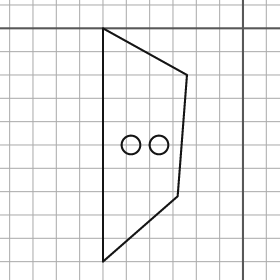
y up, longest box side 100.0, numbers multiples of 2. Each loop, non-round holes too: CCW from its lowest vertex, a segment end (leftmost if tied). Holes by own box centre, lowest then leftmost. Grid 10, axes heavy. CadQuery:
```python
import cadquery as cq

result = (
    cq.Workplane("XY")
    .moveTo(-60.0, -100.0)
    .lineTo(-28.0, -72.0)
    .lineTo(-24.0, -20.0)
    .lineTo(-60.0, 0.0)
    .close()
    .moveTo(-48.0, -50.0)
    .circle(4.0)
    .moveTo(-36.0, -50.0)
    .circle(4.0)
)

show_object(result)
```